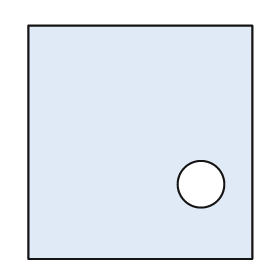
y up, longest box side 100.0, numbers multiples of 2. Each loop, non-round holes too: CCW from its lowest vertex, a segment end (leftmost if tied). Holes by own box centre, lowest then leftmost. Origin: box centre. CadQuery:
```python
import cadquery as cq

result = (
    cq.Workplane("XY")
    .moveTo(-48.0, -50.0)
    .lineTo(48.0, -50.0)
    .lineTo(48.0, 50.0)
    .lineTo(-48.0, 50.0)
    .close()
    .moveTo(26.0, -18.0)
    .circle(10.0)
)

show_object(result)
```